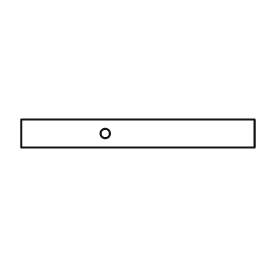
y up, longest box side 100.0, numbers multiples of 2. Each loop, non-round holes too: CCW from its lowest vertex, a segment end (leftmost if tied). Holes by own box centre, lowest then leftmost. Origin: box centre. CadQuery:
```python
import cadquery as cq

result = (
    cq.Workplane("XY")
    .moveTo(-50.0, -6.0)
    .lineTo(50.0, -6.0)
    .lineTo(50.0, 6.0)
    .lineTo(-50.0, 6.0)
    .close()
    .moveTo(-14.0, 0.0)
    .circle(2.0)
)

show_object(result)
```